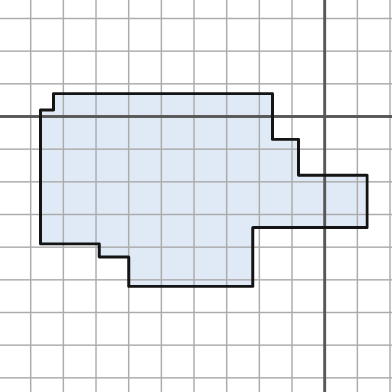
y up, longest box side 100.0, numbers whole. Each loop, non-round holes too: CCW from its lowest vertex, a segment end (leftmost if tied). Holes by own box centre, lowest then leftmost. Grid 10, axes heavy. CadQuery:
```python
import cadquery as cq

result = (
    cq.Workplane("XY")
    .moveTo(-60.0, -52.0)
    .lineTo(-22.0, -52.0)
    .lineTo(-22.0, -34.0)
    .lineTo(13.0, -34.0)
    .lineTo(13.0, -18.0)
    .lineTo(-8.0, -18.0)
    .lineTo(-8.0, -7.0)
    .lineTo(-16.0, -7.0)
    .lineTo(-16.0, 7.0)
    .lineTo(-83.0, 7.0)
    .lineTo(-83.0, 2.0)
    .lineTo(-87.0, 2.0)
    .lineTo(-87.0, -39.0)
    .lineTo(-69.0, -39.0)
    .lineTo(-69.0, -43.0)
    .lineTo(-60.0, -43.0)
    .close()
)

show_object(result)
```